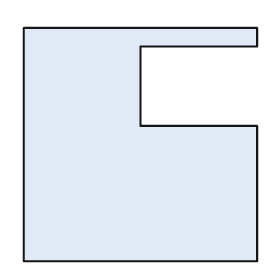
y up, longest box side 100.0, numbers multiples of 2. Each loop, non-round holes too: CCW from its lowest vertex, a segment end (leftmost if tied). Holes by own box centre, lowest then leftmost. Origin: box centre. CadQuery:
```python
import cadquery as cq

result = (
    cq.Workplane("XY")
    .moveTo(-50.0, -50.0)
    .lineTo(50.0, -50.0)
    .lineTo(50.0, 8.0)
    .lineTo(0.0, 8.0)
    .lineTo(0.0, 42.0)
    .lineTo(50.0, 42.0)
    .lineTo(50.0, 50.0)
    .lineTo(-50.0, 50.0)
    .close()
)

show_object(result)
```